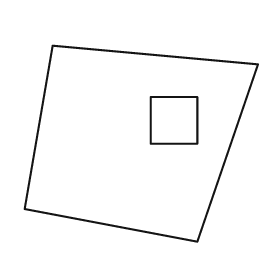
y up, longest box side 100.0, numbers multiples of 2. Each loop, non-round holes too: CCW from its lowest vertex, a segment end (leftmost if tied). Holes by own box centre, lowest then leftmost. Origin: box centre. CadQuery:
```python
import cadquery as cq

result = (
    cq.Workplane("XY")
    .moveTo(24.0, -42.0)
    .lineTo(50.0, 34.0)
    .lineTo(-38.0, 42.0)
    .lineTo(-50.0, -28.0)
    .close()
    .moveTo(4.0, 0.0)
    .lineTo(24.0, 0.0)
    .lineTo(24.0, 20.0)
    .lineTo(4.0, 20.0)
    .close()
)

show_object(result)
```